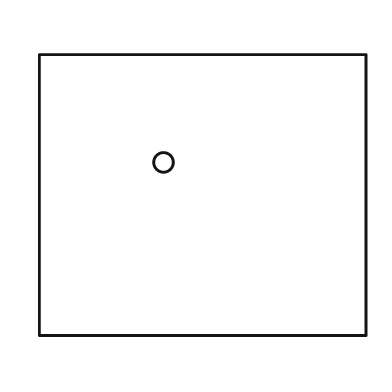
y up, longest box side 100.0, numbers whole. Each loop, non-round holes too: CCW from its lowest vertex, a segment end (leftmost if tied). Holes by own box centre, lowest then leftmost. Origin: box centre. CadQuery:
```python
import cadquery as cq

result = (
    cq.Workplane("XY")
    .moveTo(-50.0, -43.0)
    .lineTo(50.0, -43.0)
    .lineTo(50.0, 43.0)
    .lineTo(-50.0, 43.0)
    .close()
    .moveTo(-12.0, 10.0)
    .circle(3.0)
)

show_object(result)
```